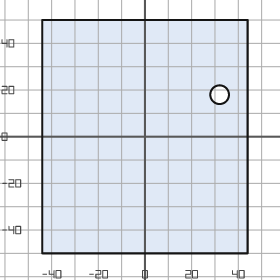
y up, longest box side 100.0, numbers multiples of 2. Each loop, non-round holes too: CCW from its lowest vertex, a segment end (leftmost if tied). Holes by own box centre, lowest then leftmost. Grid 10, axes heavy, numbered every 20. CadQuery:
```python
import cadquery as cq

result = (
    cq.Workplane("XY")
    .moveTo(-44.0, -50.0)
    .lineTo(44.0, -50.0)
    .lineTo(44.0, 50.0)
    .lineTo(-44.0, 50.0)
    .close()
    .moveTo(32.0, 18.0)
    .circle(4.0)
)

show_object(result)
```